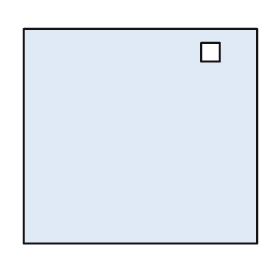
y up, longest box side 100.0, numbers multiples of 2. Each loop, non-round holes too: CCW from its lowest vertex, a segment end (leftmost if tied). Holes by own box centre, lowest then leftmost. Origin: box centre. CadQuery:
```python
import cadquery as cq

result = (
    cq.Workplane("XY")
    .moveTo(-50.0, -46.0)
    .lineTo(50.0, -46.0)
    .lineTo(50.0, 46.0)
    .lineTo(-50.0, 46.0)
    .close()
    .moveTo(26.0, 32.0)
    .lineTo(34.0, 32.0)
    .lineTo(34.0, 40.0)
    .lineTo(26.0, 40.0)
    .close()
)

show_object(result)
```